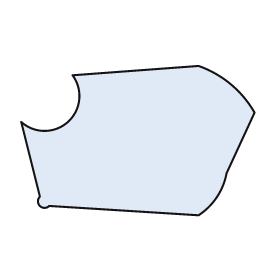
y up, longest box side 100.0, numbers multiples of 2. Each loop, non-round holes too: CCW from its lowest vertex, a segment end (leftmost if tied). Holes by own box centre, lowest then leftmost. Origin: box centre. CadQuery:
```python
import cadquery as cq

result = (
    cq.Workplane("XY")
    .moveTo(26.0, -32.0)
    .threePointArc((34.0, -24.0), (38.0, -14.0))
    .lineTo(50.0, 12.0)
    .threePointArc((40.0, 24.0), (26.0, 32.0))
    .lineTo(-28.0, 28.0)
    .threePointArc((-30.0, 8.0), (-50.0, 8.0))
    .lineTo(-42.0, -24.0)
    .threePointArc((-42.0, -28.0), (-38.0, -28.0))
    .close()
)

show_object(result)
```